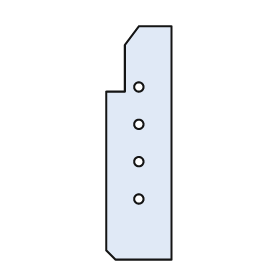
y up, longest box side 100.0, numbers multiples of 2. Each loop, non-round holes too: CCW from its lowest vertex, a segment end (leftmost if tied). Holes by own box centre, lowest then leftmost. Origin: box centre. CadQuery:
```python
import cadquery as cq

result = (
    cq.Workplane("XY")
    .moveTo(-10.0, -50.0)
    .lineTo(14.0, -50.0)
    .lineTo(14.0, 50.0)
    .lineTo(0.0, 50.0)
    .lineTo(-6.0, 42.0)
    .lineTo(-6.0, 22.0)
    .lineTo(-14.0, 22.0)
    .lineTo(-14.0, -46.0)
    .close()
    .moveTo(0.0, -24.0)
    .circle(2.0)
    .moveTo(0.0, -8.0)
    .circle(2.0)
    .moveTo(0.0, 8.0)
    .circle(2.0)
    .moveTo(0.0, 24.0)
    .circle(2.0)
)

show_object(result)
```